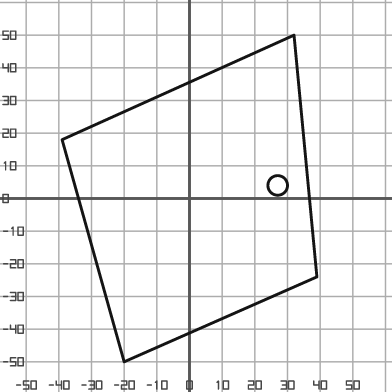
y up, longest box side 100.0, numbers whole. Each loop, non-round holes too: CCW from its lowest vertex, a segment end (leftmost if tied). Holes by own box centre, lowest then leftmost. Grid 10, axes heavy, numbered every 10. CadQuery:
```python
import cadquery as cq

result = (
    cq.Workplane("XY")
    .moveTo(-20.0, -50.0)
    .lineTo(39.0, -24.0)
    .lineTo(32.0, 50.0)
    .lineTo(-39.0, 18.0)
    .close()
    .moveTo(27.0, 4.0)
    .circle(3.0)
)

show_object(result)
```